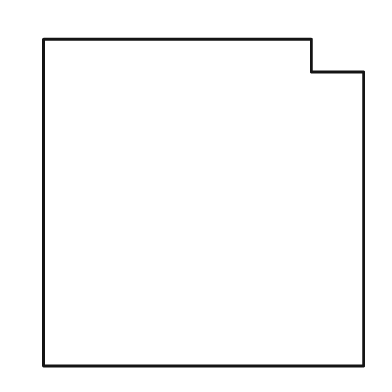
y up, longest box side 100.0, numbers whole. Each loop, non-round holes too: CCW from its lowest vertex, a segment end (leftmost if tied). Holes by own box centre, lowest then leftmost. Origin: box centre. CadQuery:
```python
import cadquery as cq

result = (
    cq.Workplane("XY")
    .moveTo(-49.0, -50.0)
    .lineTo(49.0, -50.0)
    .lineTo(49.0, 40.0)
    .lineTo(33.0, 40.0)
    .lineTo(33.0, 50.0)
    .lineTo(-49.0, 50.0)
    .close()
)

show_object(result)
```